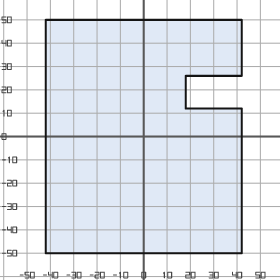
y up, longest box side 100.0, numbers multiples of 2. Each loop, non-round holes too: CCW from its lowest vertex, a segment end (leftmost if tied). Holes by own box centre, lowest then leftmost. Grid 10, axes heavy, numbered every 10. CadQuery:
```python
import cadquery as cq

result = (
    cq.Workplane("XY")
    .moveTo(-42.0, -50.0)
    .lineTo(42.0, -50.0)
    .lineTo(42.0, 12.0)
    .lineTo(18.0, 12.0)
    .lineTo(18.0, 26.0)
    .lineTo(42.0, 26.0)
    .lineTo(42.0, 50.0)
    .lineTo(-42.0, 50.0)
    .close()
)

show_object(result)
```